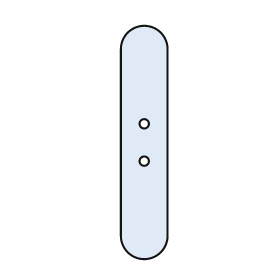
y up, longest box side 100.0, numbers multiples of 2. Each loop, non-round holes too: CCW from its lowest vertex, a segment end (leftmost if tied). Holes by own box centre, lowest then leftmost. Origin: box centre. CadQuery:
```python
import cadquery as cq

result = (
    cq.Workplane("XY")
    .moveTo(-10.0, -40.0)
    .threePointArc((0.0, -50.0), (10.0, -40.0))
    .lineTo(10.0, 40.0)
    .threePointArc((0.0, 50.0), (-10.0, 40.0))
    .close()
    .moveTo(0.0, -8.0)
    .circle(2.0)
    .moveTo(0.0, 8.0)
    .circle(2.0)
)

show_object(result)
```